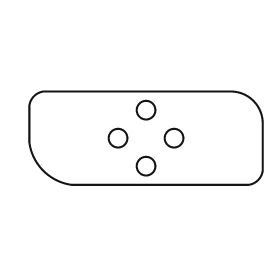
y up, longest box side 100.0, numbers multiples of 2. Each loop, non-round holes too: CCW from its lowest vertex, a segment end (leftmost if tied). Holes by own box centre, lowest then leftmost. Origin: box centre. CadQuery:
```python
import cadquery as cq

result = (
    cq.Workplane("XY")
    .moveTo(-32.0, -20.0)
    .lineTo(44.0, -20.0)
    .threePointArc((48.0, -18.0), (50.0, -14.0))
    .lineTo(50.0, 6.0)
    .threePointArc((46.0, 16.0), (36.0, 20.0))
    .lineTo(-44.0, 20.0)
    .threePointArc((-48.0, 18.0), (-50.0, 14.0))
    .lineTo(-50.0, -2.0)
    .threePointArc((-44.0, -14.0), (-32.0, -20.0))
    .close()
    .moveTo(0.0, -12.0)
    .circle(4.0)
    .moveTo(-12.0, 0.0)
    .circle(4.0)
    .moveTo(12.0, 0.0)
    .circle(4.0)
    .moveTo(0.0, 12.0)
    .circle(4.0)
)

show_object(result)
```